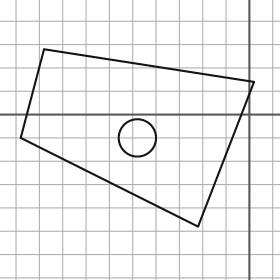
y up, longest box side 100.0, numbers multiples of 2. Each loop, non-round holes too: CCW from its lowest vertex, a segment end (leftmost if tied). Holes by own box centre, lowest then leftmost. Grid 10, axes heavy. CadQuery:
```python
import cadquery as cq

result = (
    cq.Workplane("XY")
    .moveTo(-22.0, -48.0)
    .lineTo(2.0, 14.0)
    .lineTo(-88.0, 28.0)
    .lineTo(-98.0, -10.0)
    .close()
    .moveTo(-48.0, -10.0)
    .circle(8.0)
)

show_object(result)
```